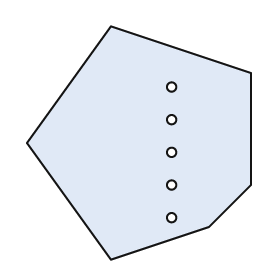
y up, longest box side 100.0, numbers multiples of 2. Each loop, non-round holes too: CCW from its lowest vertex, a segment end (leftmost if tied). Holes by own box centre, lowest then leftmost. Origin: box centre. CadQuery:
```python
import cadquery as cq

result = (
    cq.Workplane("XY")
    .moveTo(-12.0, -50.0)
    .lineTo(30.0, -36.0)
    .lineTo(48.0, -18.0)
    .lineTo(48.0, 30.0)
    .lineTo(-12.0, 50.0)
    .lineTo(-48.0, 0.0)
    .close()
    .moveTo(14.0, -32.0)
    .circle(2.0)
    .moveTo(14.0, -18.0)
    .circle(2.0)
    .moveTo(14.0, -4.0)
    .circle(2.0)
    .moveTo(14.0, 10.0)
    .circle(2.0)
    .moveTo(14.0, 24.0)
    .circle(2.0)
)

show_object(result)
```